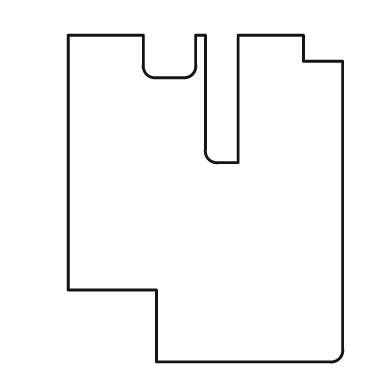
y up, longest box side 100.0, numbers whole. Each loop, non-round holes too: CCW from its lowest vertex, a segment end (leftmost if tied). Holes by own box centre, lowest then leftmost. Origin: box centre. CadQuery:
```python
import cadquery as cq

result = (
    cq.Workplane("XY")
    .moveTo(-15.0, -50.0)
    .lineTo(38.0, -50.0)
    .threePointArc((41.0, -49.0), (42.0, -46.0))
    .lineTo(42.0, 42.0)
    .lineTo(30.0, 42.0)
    .lineTo(30.0, 50.0)
    .lineTo(10.0, 50.0)
    .lineTo(10.0, 11.0)
    .lineTo(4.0, 11.0)
    .threePointArc((1.0, 12.0), (0.0, 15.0))
    .lineTo(0.0, 50.0)
    .lineTo(-3.0, 50.0)
    .lineTo(-3.0, 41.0)
    .threePointArc((-4.0, 38.0), (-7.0, 37.0))
    .lineTo(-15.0, 37.0)
    .threePointArc((-18.0, 38.0), (-19.0, 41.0))
    .lineTo(-19.0, 50.0)
    .lineTo(-42.0, 50.0)
    .lineTo(-42.0, -28.0)
    .lineTo(-15.0, -28.0)
    .close()
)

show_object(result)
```